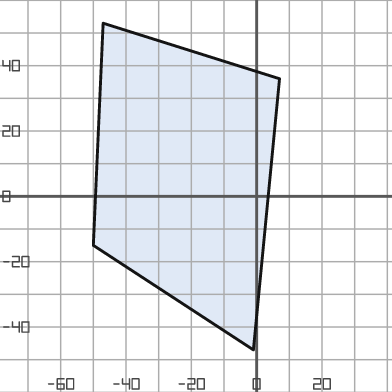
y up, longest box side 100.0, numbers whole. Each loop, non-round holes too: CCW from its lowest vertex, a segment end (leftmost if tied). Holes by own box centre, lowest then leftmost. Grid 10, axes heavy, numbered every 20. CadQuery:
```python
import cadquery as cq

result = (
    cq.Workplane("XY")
    .moveTo(-1.0, -47.0)
    .lineTo(7.0, 36.0)
    .lineTo(-47.0, 53.0)
    .lineTo(-50.0, -15.0)
    .close()
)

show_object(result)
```